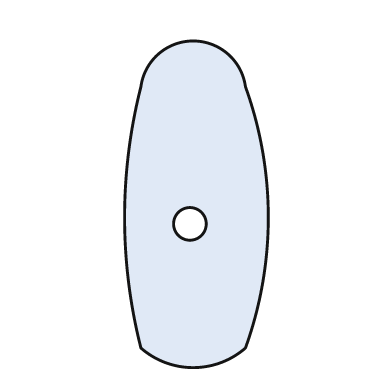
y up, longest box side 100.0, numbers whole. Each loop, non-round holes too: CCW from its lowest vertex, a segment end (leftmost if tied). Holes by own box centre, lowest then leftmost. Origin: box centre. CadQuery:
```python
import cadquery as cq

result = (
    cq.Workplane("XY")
    .moveTo(-17.0, -44.0)
    .threePointArc((-1.0, -50.0), (15.0, -44.0))
    .threePointArc((22.0, -4.0), (15.0, 36.0))
    .threePointArc((-1.0, 50.0), (-17.0, 36.0))
    .threePointArc((-22.0, -4.0), (-17.0, -44.0))
    .close()
    .moveTo(-2.0, -6.0)
    .circle(5.0)
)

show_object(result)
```